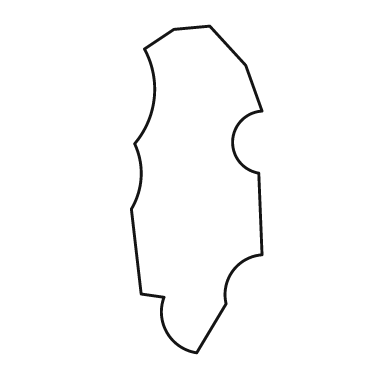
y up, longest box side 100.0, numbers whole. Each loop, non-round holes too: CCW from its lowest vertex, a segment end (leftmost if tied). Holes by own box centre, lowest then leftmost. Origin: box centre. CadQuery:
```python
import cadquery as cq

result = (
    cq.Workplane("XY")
    .moveTo(0.0, -50.0)
    .lineTo(9.0, -35.0)
    .threePointArc((11.0, -25.0), (20.0, -20.0))
    .lineTo(19.0, 5.0)
    .threePointArc((11.0, 15.0), (20.0, 24.0))
    .lineTo(15.0, 38.0)
    .lineTo(4.0, 50.0)
    .lineTo(-7.0, 49.0)
    .lineTo(-16.0, 43.0)
    .threePointArc((-13.0, 28.0), (-19.0, 14.0))
    .threePointArc((-17.0, 4.0), (-20.0, -6.0))
    .lineTo(-17.0, -32.0)
    .lineTo(-10.0, -33.0)
    .threePointArc((-9.0, -44.0), (0.0, -50.0))
    .close()
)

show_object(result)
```